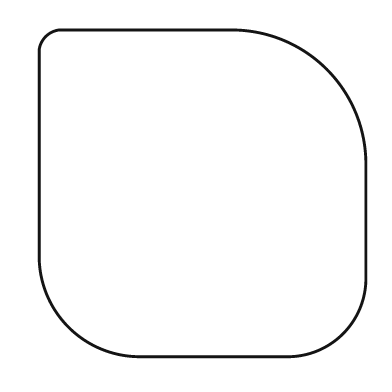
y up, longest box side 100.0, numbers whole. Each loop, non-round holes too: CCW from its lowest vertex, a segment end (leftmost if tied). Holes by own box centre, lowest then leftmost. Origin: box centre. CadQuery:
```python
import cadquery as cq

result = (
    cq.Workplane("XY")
    .moveTo(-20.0, -50.0)
    .lineTo(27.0, -50.0)
    .threePointArc((43.0, -43.0), (50.0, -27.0))
    .lineTo(50.0, 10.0)
    .threePointArc((38.0, 38.0), (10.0, 50.0))
    .lineTo(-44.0, 50.0)
    .threePointArc((-48.0, 48.0), (-50.0, 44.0))
    .lineTo(-50.0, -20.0)
    .threePointArc((-41.0, -41.0), (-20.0, -50.0))
    .close()
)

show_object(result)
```